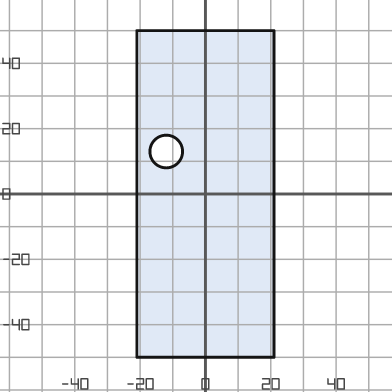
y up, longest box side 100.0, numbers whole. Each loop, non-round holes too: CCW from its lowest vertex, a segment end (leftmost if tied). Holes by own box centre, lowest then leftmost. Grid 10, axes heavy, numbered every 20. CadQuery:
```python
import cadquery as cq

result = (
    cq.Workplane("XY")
    .moveTo(-21.0, -50.0)
    .lineTo(21.0, -50.0)
    .lineTo(21.0, 50.0)
    .lineTo(-21.0, 50.0)
    .close()
    .moveTo(-12.0, 13.0)
    .circle(5.0)
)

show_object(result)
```